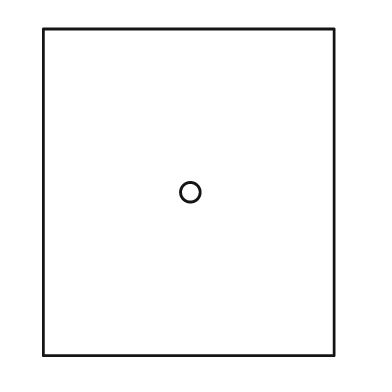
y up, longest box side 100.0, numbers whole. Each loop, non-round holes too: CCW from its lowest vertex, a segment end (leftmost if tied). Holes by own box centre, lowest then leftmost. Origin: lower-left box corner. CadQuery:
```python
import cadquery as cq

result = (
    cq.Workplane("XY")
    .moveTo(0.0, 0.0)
    .lineTo(89.0, 0.0)
    .lineTo(89.0, 100.0)
    .lineTo(0.0, 100.0)
    .close()
    .moveTo(45.0, 50.0)
    .circle(3.0)
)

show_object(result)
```